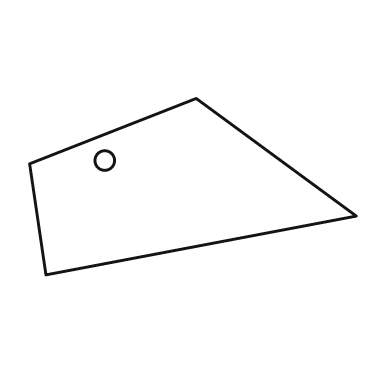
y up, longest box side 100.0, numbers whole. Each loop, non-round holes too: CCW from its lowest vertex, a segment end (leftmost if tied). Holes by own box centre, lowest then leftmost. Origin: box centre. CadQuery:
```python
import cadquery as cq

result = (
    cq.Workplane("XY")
    .moveTo(-45.0, -27.0)
    .lineTo(50.0, -9.0)
    .lineTo(1.0, 27.0)
    .lineTo(-50.0, 7.0)
    .close()
    .moveTo(-27.0, 8.0)
    .circle(3.0)
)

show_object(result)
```